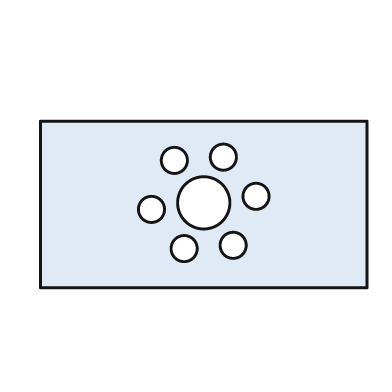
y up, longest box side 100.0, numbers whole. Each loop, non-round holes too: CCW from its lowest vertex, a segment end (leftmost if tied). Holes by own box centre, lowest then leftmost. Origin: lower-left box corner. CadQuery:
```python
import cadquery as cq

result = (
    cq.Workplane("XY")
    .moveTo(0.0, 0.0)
    .lineTo(100.0, 0.0)
    .lineTo(100.0, 51.0)
    .lineTo(0.0, 51.0)
    .close()
    .moveTo(44.0, 12.0)
    .circle(4.0)
    .moveTo(59.0, 13.0)
    .circle(4.0)
    .moveTo(34.0, 24.0)
    .circle(4.0)
    .moveTo(50.0, 26.0)
    .circle(8.0)
    .moveTo(66.0, 28.0)
    .circle(4.0)
    .moveTo(41.0, 39.0)
    .circle(4.0)
    .moveTo(56.0, 40.0)
    .circle(4.0)
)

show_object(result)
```